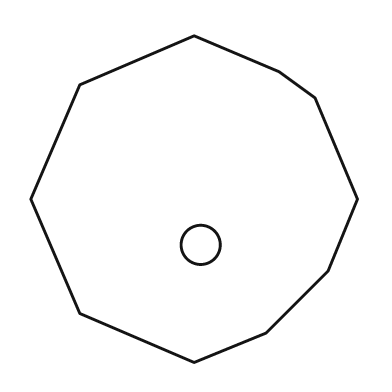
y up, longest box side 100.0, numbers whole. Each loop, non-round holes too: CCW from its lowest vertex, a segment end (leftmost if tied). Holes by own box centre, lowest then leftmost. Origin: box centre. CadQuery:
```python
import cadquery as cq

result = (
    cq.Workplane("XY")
    .moveTo(0.0, -50.0)
    .lineTo(22.0, -41.0)
    .lineTo(41.0, -22.0)
    .lineTo(50.0, 0.0)
    .lineTo(37.0, 31.0)
    .lineTo(26.0, 39.0)
    .lineTo(0.0, 50.0)
    .lineTo(-35.0, 35.0)
    .lineTo(-50.0, 0.0)
    .lineTo(-35.0, -35.0)
    .close()
    .moveTo(2.0, -14.0)
    .circle(6.0)
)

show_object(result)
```